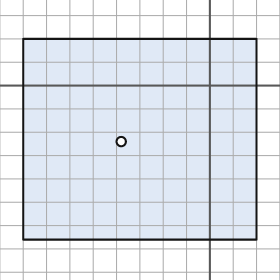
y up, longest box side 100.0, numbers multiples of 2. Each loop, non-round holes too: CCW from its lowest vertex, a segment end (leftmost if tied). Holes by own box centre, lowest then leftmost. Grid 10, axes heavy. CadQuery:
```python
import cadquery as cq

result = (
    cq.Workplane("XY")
    .moveTo(-80.0, -66.0)
    .lineTo(20.0, -66.0)
    .lineTo(20.0, 20.0)
    .lineTo(-80.0, 20.0)
    .close()
    .moveTo(-38.0, -24.0)
    .circle(2.0)
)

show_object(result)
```